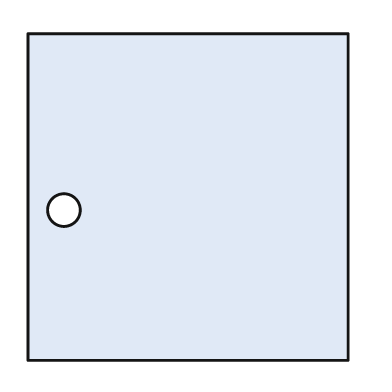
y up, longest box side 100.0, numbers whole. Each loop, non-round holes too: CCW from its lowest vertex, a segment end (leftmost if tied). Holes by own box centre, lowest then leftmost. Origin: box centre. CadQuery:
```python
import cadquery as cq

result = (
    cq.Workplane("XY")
    .moveTo(-49.0, -50.0)
    .lineTo(49.0, -50.0)
    .lineTo(49.0, 50.0)
    .lineTo(-49.0, 50.0)
    .close()
    .moveTo(-38.0, -4.0)
    .circle(5.0)
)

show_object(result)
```